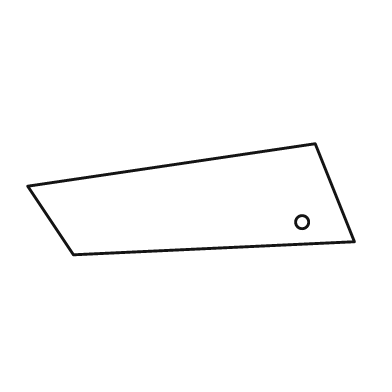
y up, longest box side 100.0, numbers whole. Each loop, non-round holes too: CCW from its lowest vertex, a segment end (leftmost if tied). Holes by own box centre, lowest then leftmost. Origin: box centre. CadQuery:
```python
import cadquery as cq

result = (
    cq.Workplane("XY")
    .moveTo(-36.0, -17.0)
    .lineTo(50.0, -13.0)
    .lineTo(38.0, 17.0)
    .lineTo(-50.0, 4.0)
    .close()
    .moveTo(34.0, -7.0)
    .circle(2.0)
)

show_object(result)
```